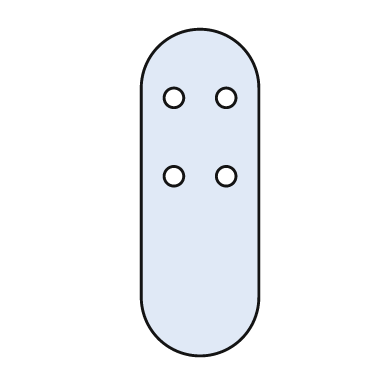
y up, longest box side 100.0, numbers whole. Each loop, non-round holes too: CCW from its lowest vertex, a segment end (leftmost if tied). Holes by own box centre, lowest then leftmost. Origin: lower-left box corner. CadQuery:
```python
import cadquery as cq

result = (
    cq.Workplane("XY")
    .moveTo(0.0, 18.0)
    .threePointArc((18.0, 0.0), (36.0, 18.0))
    .lineTo(36.0, 82.0)
    .threePointArc((18.0, 100.0), (0.0, 82.0))
    .close()
    .moveTo(10.0, 55.0)
    .circle(3.0)
    .moveTo(26.0, 55.0)
    .circle(3.0)
    .moveTo(10.0, 79.0)
    .circle(3.0)
    .moveTo(26.0, 79.0)
    .circle(3.0)
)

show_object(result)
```